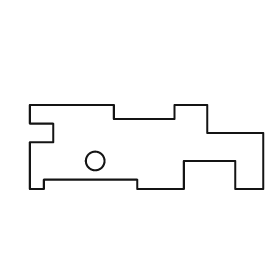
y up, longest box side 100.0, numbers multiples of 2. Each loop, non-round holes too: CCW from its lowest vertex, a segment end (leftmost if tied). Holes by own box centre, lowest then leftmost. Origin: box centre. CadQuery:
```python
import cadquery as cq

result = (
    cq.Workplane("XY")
    .moveTo(-50.0, -18.0)
    .lineTo(-44.0, -18.0)
    .lineTo(-44.0, -14.0)
    .lineTo(-4.0, -14.0)
    .lineTo(-4.0, -18.0)
    .lineTo(16.0, -18.0)
    .lineTo(16.0, -6.0)
    .lineTo(38.0, -6.0)
    .lineTo(38.0, -18.0)
    .lineTo(50.0, -18.0)
    .lineTo(50.0, 6.0)
    .lineTo(26.0, 6.0)
    .lineTo(26.0, 18.0)
    .lineTo(12.0, 18.0)
    .lineTo(12.0, 12.0)
    .lineTo(-14.0, 12.0)
    .lineTo(-14.0, 18.0)
    .lineTo(-50.0, 18.0)
    .lineTo(-50.0, 10.0)
    .lineTo(-40.0, 10.0)
    .lineTo(-40.0, 2.0)
    .lineTo(-50.0, 2.0)
    .close()
    .moveTo(-22.0, -6.0)
    .circle(4.0)
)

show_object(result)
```